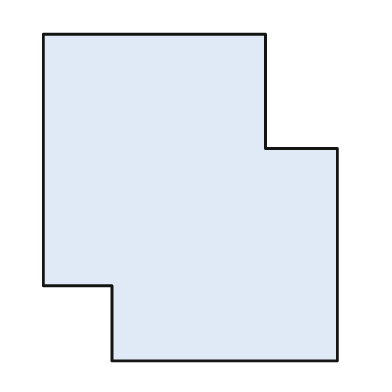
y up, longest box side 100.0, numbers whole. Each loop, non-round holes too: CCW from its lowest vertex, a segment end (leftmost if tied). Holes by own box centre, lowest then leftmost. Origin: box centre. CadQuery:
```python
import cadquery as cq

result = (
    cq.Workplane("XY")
    .moveTo(-24.0, -50.0)
    .lineTo(45.0, -50.0)
    .lineTo(45.0, 15.0)
    .lineTo(23.0, 15.0)
    .lineTo(23.0, 50.0)
    .lineTo(-45.0, 50.0)
    .lineTo(-45.0, -27.0)
    .lineTo(-24.0, -27.0)
    .close()
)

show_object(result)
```